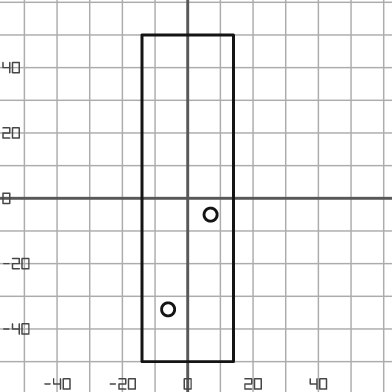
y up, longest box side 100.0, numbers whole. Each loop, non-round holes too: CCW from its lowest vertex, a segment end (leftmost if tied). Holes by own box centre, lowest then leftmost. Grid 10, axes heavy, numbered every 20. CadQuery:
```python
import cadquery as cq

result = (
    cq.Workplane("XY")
    .moveTo(-14.0, -50.0)
    .lineTo(14.0, -50.0)
    .lineTo(14.0, 50.0)
    .lineTo(-14.0, 50.0)
    .close()
    .moveTo(-6.0, -34.0)
    .circle(2.0)
    .moveTo(7.0, -5.0)
    .circle(2.0)
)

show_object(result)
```